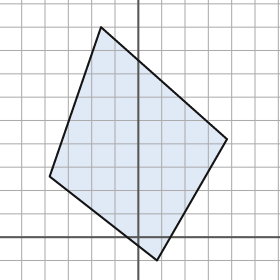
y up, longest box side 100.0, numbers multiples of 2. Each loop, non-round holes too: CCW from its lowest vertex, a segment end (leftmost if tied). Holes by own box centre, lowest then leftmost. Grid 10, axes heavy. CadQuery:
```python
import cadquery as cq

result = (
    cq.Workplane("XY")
    .moveTo(8.0, -10.0)
    .lineTo(38.0, 42.0)
    .lineTo(-16.0, 90.0)
    .lineTo(-38.0, 26.0)
    .close()
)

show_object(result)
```